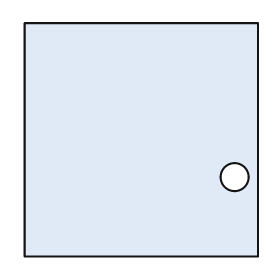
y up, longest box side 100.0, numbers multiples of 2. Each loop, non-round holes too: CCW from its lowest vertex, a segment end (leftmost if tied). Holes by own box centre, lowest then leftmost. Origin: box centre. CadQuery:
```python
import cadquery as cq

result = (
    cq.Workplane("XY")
    .moveTo(-50.0, -50.0)
    .lineTo(50.0, -50.0)
    .lineTo(50.0, 50.0)
    .lineTo(-50.0, 50.0)
    .close()
    .moveTo(40.0, -16.0)
    .circle(6.0)
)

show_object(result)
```